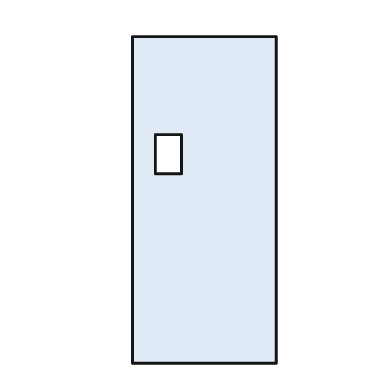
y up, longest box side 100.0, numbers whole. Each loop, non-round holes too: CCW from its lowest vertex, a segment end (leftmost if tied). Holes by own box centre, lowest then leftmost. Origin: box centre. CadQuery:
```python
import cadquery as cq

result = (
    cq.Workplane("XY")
    .moveTo(-22.0, -50.0)
    .lineTo(22.0, -50.0)
    .lineTo(22.0, 50.0)
    .lineTo(-22.0, 50.0)
    .close()
    .moveTo(-15.0, 8.0)
    .lineTo(-7.0, 8.0)
    .lineTo(-7.0, 20.0)
    .lineTo(-15.0, 20.0)
    .close()
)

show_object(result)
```